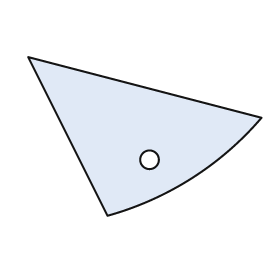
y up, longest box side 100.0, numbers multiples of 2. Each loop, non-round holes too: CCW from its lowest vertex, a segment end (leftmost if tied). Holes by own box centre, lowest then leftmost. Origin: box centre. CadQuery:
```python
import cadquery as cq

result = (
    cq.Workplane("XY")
    .moveTo(-16.0, -34.0)
    .threePointArc((20.0, -18.0), (50.0, 8.0))
    .lineTo(-50.0, 34.0)
    .close()
    .moveTo(2.0, -10.0)
    .circle(4.0)
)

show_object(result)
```